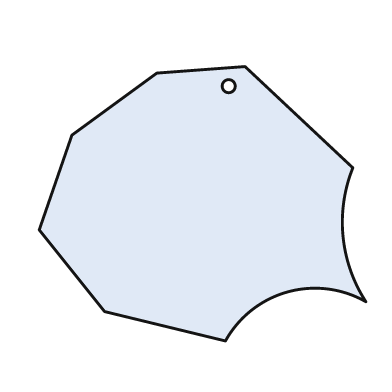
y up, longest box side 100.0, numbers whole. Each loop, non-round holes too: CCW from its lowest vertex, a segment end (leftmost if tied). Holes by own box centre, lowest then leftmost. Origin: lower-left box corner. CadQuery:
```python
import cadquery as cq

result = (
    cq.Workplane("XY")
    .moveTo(57.0, 0.0)
    .threePointArc((76.0, 15.0), (100.0, 12.0))
    .threePointArc((93.0, 32.0), (96.0, 53.0))
    .lineTo(63.0, 84.0)
    .lineTo(36.0, 82.0)
    .lineTo(10.0, 63.0)
    .lineTo(0.0, 34.0)
    .lineTo(20.0, 9.0)
    .close()
    .moveTo(58.0, 78.0)
    .circle(2.0)
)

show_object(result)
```